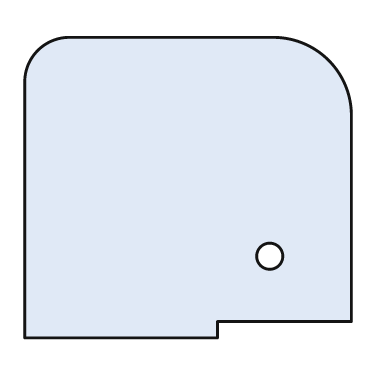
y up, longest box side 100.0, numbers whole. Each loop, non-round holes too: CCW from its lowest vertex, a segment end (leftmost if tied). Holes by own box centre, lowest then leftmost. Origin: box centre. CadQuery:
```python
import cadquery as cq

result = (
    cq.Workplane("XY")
    .moveTo(-50.0, -46.0)
    .lineTo(9.0, -46.0)
    .lineTo(9.0, -41.0)
    .lineTo(50.0, -41.0)
    .lineTo(50.0, 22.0)
    .threePointArc((43.0, 39.0), (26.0, 46.0))
    .lineTo(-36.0, 46.0)
    .threePointArc((-46.0, 42.0), (-50.0, 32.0))
    .close()
    .moveTo(25.0, -21.0)
    .circle(4.0)
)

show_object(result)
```